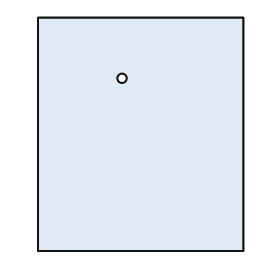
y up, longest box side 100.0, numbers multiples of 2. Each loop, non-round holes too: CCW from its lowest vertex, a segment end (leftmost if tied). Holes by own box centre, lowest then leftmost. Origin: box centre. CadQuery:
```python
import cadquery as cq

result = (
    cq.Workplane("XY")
    .moveTo(-44.0, -50.0)
    .lineTo(44.0, -50.0)
    .lineTo(44.0, 50.0)
    .lineTo(-44.0, 50.0)
    .close()
    .moveTo(-8.0, 24.0)
    .circle(2.0)
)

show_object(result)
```